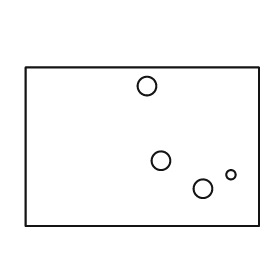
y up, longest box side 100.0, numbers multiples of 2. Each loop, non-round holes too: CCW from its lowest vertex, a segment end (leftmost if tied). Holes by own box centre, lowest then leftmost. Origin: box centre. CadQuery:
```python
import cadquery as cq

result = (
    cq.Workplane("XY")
    .moveTo(-50.0, -34.0)
    .lineTo(50.0, -34.0)
    .lineTo(50.0, 34.0)
    .lineTo(-50.0, 34.0)
    .close()
    .moveTo(26.0, -18.0)
    .circle(4.0)
    .moveTo(38.0, -12.0)
    .circle(2.0)
    .moveTo(8.0, -6.0)
    .circle(4.0)
    .moveTo(2.0, 26.0)
    .circle(4.0)
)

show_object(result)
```